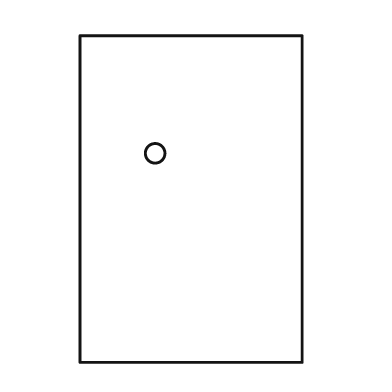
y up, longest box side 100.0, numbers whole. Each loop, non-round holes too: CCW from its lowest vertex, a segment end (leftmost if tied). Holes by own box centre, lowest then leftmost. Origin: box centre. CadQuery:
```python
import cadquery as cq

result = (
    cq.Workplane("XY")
    .moveTo(-34.0, -50.0)
    .lineTo(34.0, -50.0)
    .lineTo(34.0, 50.0)
    .lineTo(-34.0, 50.0)
    .close()
    .moveTo(-11.0, 14.0)
    .circle(3.0)
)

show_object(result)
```